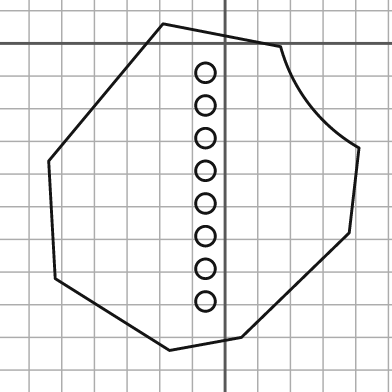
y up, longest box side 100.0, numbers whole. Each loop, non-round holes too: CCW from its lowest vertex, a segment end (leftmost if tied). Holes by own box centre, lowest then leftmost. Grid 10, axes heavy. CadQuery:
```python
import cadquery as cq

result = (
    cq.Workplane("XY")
    .moveTo(-17.0, -94.0)
    .lineTo(5.0, -90.0)
    .lineTo(38.0, -58.0)
    .lineTo(41.0, -32.0)
    .threePointArc((26.0, -19.0), (17.0, -1.0))
    .lineTo(-19.0, 6.0)
    .lineTo(-54.0, -36.0)
    .lineTo(-52.0, -72.0)
    .close()
    .moveTo(-6.0, -79.0)
    .circle(3.0)
    .moveTo(-6.0, -69.0)
    .circle(3.0)
    .moveTo(-6.0, -59.0)
    .circle(3.0)
    .moveTo(-6.0, -49.0)
    .circle(3.0)
    .moveTo(-6.0, -39.0)
    .circle(3.0)
    .moveTo(-6.0, -29.0)
    .circle(3.0)
    .moveTo(-6.0, -19.0)
    .circle(3.0)
    .moveTo(-6.0, -9.0)
    .circle(3.0)
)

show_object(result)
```